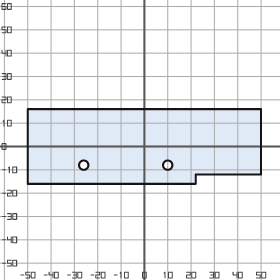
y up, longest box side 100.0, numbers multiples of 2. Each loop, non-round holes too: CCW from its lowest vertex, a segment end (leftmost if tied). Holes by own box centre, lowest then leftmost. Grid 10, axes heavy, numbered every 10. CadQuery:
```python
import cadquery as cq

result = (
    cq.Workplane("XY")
    .moveTo(-50.0, -16.0)
    .lineTo(22.0, -16.0)
    .lineTo(22.0, -12.0)
    .lineTo(50.0, -12.0)
    .lineTo(50.0, 16.0)
    .lineTo(-50.0, 16.0)
    .close()
    .moveTo(-26.0, -8.0)
    .circle(2.0)
    .moveTo(10.0, -8.0)
    .circle(2.0)
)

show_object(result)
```